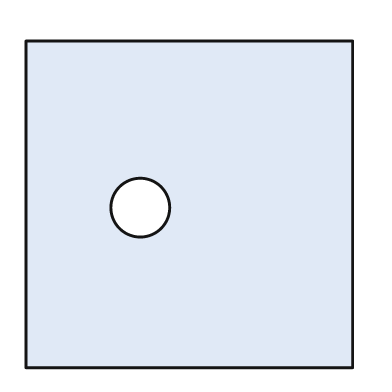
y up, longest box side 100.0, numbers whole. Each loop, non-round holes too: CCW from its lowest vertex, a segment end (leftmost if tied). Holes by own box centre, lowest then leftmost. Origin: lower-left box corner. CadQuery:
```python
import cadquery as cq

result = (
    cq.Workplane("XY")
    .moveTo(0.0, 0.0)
    .lineTo(100.0, 0.0)
    .lineTo(100.0, 100.0)
    .lineTo(0.0, 100.0)
    .close()
    .moveTo(35.0, 49.0)
    .circle(9.0)
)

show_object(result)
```